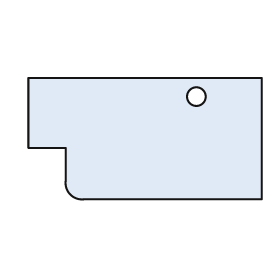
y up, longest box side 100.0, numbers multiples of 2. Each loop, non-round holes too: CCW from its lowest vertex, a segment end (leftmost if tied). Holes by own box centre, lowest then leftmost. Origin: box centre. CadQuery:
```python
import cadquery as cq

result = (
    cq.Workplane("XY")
    .moveTo(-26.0, -26.0)
    .lineTo(50.0, -26.0)
    .lineTo(50.0, 26.0)
    .lineTo(-50.0, 26.0)
    .lineTo(-50.0, -4.0)
    .lineTo(-34.0, -4.0)
    .lineTo(-34.0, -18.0)
    .threePointArc((-32.0, -24.0), (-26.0, -26.0))
    .close()
    .moveTo(22.0, 18.0)
    .circle(4.0)
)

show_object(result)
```